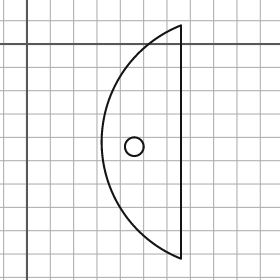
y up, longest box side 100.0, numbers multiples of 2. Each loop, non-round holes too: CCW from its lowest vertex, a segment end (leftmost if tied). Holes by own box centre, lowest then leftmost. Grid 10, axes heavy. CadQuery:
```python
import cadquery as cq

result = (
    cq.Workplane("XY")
    .moveTo(66.0, -92.0)
    .lineTo(66.0, 8.0)
    .threePointArc((32.0, -42.0), (66.0, -92.0))
    .close()
    .moveTo(46.0, -44.0)
    .circle(4.0)
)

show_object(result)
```